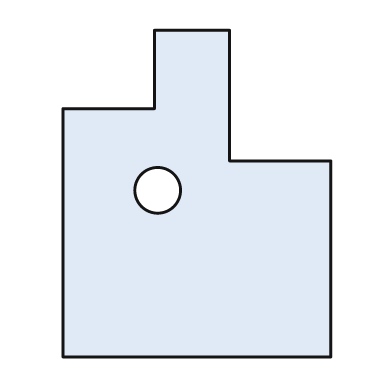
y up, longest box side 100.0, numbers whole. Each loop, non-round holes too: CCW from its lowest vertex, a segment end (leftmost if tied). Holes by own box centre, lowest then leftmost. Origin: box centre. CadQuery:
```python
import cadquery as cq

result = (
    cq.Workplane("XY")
    .moveTo(-41.0, -50.0)
    .lineTo(41.0, -50.0)
    .lineTo(41.0, 10.0)
    .lineTo(10.0, 10.0)
    .lineTo(10.0, 50.0)
    .lineTo(-13.0, 50.0)
    .lineTo(-13.0, 26.0)
    .lineTo(-41.0, 26.0)
    .close()
    .moveTo(-12.0, 1.0)
    .circle(7.0)
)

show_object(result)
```